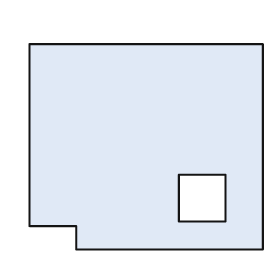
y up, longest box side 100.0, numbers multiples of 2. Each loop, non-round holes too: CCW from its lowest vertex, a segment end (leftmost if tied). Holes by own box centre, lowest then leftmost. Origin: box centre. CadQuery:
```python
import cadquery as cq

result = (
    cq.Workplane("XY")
    .moveTo(-30.0, -44.0)
    .lineTo(50.0, -44.0)
    .lineTo(50.0, 44.0)
    .lineTo(-50.0, 44.0)
    .lineTo(-50.0, -34.0)
    .lineTo(-30.0, -34.0)
    .close()
    .moveTo(14.0, -32.0)
    .lineTo(34.0, -32.0)
    .lineTo(34.0, -12.0)
    .lineTo(14.0, -12.0)
    .close()
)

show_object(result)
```